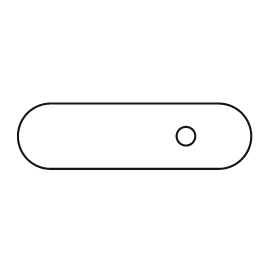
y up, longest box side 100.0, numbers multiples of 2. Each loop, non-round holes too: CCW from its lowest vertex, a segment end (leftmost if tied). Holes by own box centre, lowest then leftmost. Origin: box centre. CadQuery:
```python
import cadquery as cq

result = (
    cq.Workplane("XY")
    .moveTo(-36.0, -14.0)
    .lineTo(36.0, -14.0)
    .threePointArc((50.0, 0.0), (36.0, 14.0))
    .lineTo(-36.0, 14.0)
    .threePointArc((-50.0, 0.0), (-36.0, -14.0))
    .close()
    .moveTo(22.0, 0.0)
    .circle(4.0)
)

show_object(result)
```